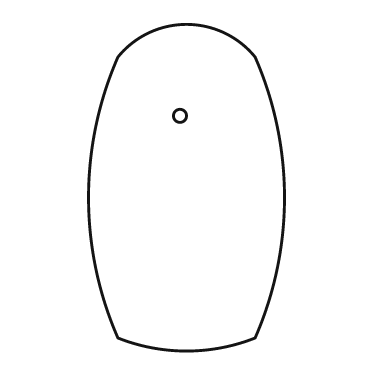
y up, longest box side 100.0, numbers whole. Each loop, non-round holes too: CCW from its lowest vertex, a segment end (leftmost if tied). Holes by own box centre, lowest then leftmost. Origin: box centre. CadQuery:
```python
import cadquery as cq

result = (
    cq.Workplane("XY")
    .moveTo(-21.0, -46.0)
    .threePointArc((0.0, -50.0), (21.0, -46.0))
    .threePointArc((30.0, -3.0), (21.0, 40.0))
    .threePointArc((0.0, 50.0), (-21.0, 40.0))
    .threePointArc((-30.0, -3.0), (-21.0, -46.0))
    .close()
    .moveTo(-2.0, 22.0)
    .circle(2.0)
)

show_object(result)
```